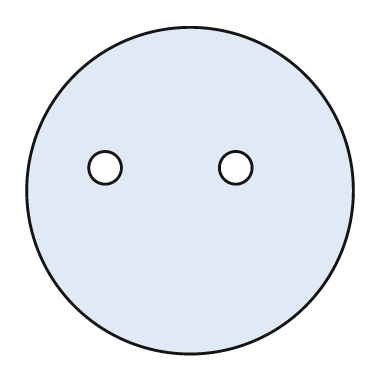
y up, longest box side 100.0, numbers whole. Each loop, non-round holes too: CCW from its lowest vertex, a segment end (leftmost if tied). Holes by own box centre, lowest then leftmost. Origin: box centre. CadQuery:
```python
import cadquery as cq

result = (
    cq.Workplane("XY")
    .moveTo(0.0, 0.0)
    .circle(50.0)
    .moveTo(-26.0, 7.0)
    .circle(5.0)
    .moveTo(14.0, 7.0)
    .circle(5.0)
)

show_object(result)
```